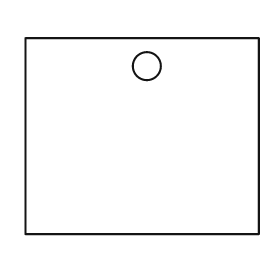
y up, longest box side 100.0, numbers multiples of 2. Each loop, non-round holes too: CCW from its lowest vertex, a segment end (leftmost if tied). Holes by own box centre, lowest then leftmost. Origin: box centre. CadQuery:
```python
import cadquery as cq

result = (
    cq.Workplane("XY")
    .moveTo(-50.0, -42.0)
    .lineTo(50.0, -42.0)
    .lineTo(50.0, 42.0)
    .lineTo(-50.0, 42.0)
    .close()
    .moveTo(2.0, 30.0)
    .circle(6.0)
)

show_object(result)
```